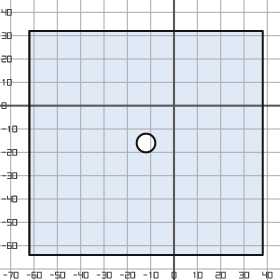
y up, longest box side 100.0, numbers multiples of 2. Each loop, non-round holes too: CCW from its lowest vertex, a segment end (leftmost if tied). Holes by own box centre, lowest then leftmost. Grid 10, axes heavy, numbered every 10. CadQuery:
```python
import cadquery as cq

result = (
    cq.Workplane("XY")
    .moveTo(-62.0, -64.0)
    .lineTo(38.0, -64.0)
    .lineTo(38.0, 32.0)
    .lineTo(-62.0, 32.0)
    .close()
    .moveTo(-12.0, -16.0)
    .circle(4.0)
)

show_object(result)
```